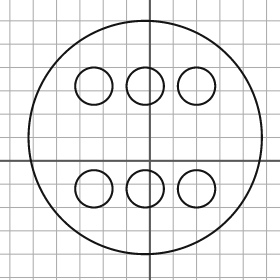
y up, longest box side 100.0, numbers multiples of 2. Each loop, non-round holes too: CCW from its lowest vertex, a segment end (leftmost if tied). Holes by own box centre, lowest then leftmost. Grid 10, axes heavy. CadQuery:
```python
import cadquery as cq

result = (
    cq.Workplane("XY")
    .moveTo(-2.0, 10.0)
    .circle(50.0)
    .moveTo(-24.0, -12.0)
    .circle(8.0)
    .moveTo(-2.0, -12.0)
    .circle(8.0)
    .moveTo(20.0, -12.0)
    .circle(8.0)
    .moveTo(-24.0, 32.0)
    .circle(8.0)
    .moveTo(-2.0, 32.0)
    .circle(8.0)
    .moveTo(20.0, 32.0)
    .circle(8.0)
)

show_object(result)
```